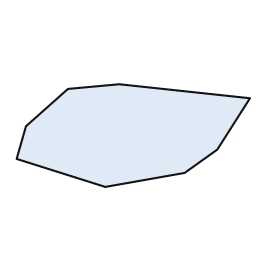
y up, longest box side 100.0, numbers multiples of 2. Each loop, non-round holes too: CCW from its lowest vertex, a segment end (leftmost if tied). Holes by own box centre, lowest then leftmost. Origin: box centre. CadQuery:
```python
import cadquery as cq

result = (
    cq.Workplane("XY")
    .moveTo(-12.0, -22.0)
    .lineTo(22.0, -16.0)
    .lineTo(36.0, -6.0)
    .lineTo(50.0, 16.0)
    .lineTo(-6.0, 22.0)
    .lineTo(-28.0, 20.0)
    .lineTo(-46.0, 4.0)
    .lineTo(-50.0, -10.0)
    .close()
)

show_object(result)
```